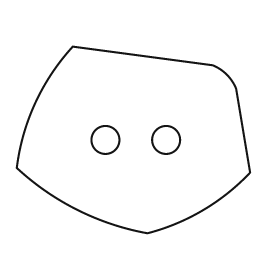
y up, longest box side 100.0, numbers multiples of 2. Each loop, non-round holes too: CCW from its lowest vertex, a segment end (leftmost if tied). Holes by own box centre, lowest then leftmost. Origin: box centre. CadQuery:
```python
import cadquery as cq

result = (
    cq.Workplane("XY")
    .moveTo(6.0, -40.0)
    .threePointArc((30.0, -30.0), (50.0, -14.0))
    .lineTo(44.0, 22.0)
    .threePointArc((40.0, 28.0), (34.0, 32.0))
    .lineTo(-26.0, 40.0)
    .threePointArc((-42.0, 16.0), (-50.0, -12.0))
    .threePointArc((-24.0, -30.0), (6.0, -40.0))
    .close()
    .moveTo(-12.0, 0.0)
    .circle(6.0)
    .moveTo(14.0, 0.0)
    .circle(6.0)
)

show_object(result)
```